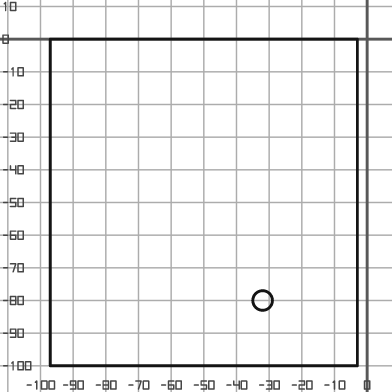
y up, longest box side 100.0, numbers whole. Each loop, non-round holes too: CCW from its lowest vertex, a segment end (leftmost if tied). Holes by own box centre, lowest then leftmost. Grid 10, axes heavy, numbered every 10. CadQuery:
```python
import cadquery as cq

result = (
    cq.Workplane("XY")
    .moveTo(-97.0, -100.0)
    .lineTo(-3.0, -100.0)
    .lineTo(-3.0, 0.0)
    .lineTo(-97.0, 0.0)
    .close()
    .moveTo(-32.0, -80.0)
    .circle(3.0)
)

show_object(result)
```